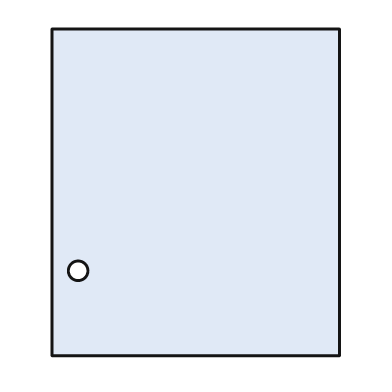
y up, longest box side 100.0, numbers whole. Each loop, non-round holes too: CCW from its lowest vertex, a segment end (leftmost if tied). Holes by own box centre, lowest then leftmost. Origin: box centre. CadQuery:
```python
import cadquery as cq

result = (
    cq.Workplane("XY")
    .moveTo(-44.0, -50.0)
    .lineTo(44.0, -50.0)
    .lineTo(44.0, 50.0)
    .lineTo(-44.0, 50.0)
    .close()
    .moveTo(-36.0, -24.0)
    .circle(3.0)
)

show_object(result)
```